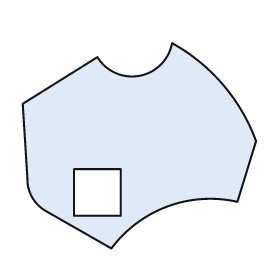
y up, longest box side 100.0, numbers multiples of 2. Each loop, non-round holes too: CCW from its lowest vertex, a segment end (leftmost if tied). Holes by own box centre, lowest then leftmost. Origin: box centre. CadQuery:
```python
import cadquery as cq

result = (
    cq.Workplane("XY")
    .moveTo(-12.0, -44.0)
    .threePointArc((12.0, -26.0), (42.0, -24.0))
    .lineTo(50.0, 2.0)
    .threePointArc((36.0, 26.0), (14.0, 44.0))
    .threePointArc((0.0, 30.0), (-18.0, 38.0))
    .lineTo(-50.0, 18.0)
    .lineTo(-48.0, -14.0)
    .threePointArc((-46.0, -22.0), (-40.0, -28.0))
    .close()
    .moveTo(-28.0, -30.0)
    .lineTo(-8.0, -30.0)
    .lineTo(-8.0, -10.0)
    .lineTo(-28.0, -10.0)
    .close()
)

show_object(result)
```